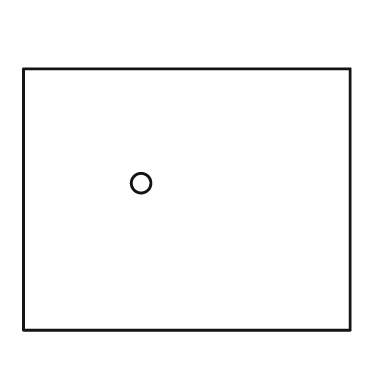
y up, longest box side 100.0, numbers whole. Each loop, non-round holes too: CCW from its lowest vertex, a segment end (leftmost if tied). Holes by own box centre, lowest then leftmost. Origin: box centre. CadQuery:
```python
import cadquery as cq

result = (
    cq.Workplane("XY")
    .moveTo(-50.0, -40.0)
    .lineTo(50.0, -40.0)
    .lineTo(50.0, 40.0)
    .lineTo(-50.0, 40.0)
    .close()
    .moveTo(-14.0, 5.0)
    .circle(3.0)
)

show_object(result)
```